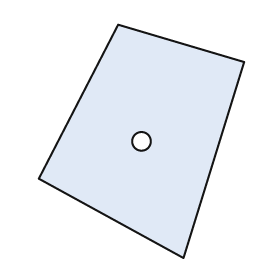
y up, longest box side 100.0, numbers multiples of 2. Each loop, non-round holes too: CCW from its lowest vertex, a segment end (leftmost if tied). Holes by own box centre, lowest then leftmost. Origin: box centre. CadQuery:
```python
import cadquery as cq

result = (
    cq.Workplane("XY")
    .moveTo(18.0, -50.0)
    .lineTo(44.0, 34.0)
    .lineTo(-10.0, 50.0)
    .lineTo(-44.0, -16.0)
    .close()
    .moveTo(0.0, 0.0)
    .circle(4.0)
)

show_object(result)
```